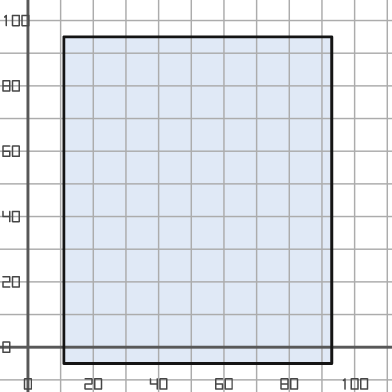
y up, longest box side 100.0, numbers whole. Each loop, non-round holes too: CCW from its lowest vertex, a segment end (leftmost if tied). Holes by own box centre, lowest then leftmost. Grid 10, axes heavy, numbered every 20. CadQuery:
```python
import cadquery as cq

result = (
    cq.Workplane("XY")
    .moveTo(11.0, -5.0)
    .lineTo(93.0, -5.0)
    .lineTo(93.0, 95.0)
    .lineTo(11.0, 95.0)
    .close()
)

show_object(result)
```